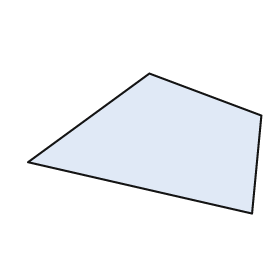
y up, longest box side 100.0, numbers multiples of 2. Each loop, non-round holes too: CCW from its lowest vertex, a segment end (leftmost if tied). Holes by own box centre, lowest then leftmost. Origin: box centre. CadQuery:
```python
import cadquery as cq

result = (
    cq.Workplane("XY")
    .moveTo(46.0, -30.0)
    .lineTo(50.0, 12.0)
    .lineTo(2.0, 30.0)
    .lineTo(-50.0, -8.0)
    .close()
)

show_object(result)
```